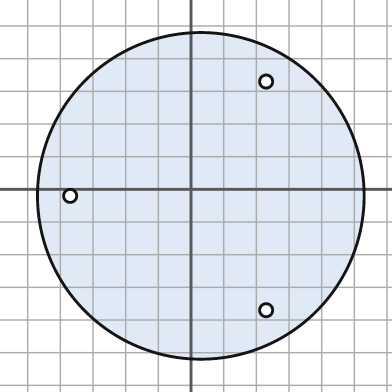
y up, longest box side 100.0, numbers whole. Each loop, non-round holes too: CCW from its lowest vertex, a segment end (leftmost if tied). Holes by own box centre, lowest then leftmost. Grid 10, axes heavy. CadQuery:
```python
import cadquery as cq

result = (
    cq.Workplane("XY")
    .moveTo(3.0, -2.0)
    .circle(50.0)
    .moveTo(23.0, -37.0)
    .circle(2.0)
    .moveTo(-37.0, -2.0)
    .circle(2.0)
    .moveTo(23.0, 33.0)
    .circle(2.0)
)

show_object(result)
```